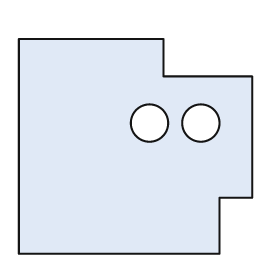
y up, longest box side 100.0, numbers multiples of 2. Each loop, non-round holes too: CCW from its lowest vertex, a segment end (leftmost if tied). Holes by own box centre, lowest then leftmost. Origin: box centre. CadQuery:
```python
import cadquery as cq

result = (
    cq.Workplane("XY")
    .moveTo(-50.0, -46.0)
    .lineTo(36.0, -46.0)
    .lineTo(36.0, -22.0)
    .lineTo(50.0, -22.0)
    .lineTo(50.0, 30.0)
    .lineTo(12.0, 30.0)
    .lineTo(12.0, 46.0)
    .lineTo(-50.0, 46.0)
    .close()
    .moveTo(6.0, 10.0)
    .circle(8.0)
    .moveTo(28.0, 10.0)
    .circle(8.0)
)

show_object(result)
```